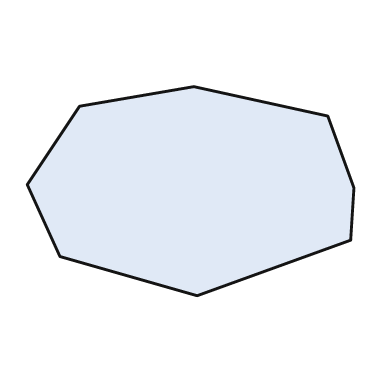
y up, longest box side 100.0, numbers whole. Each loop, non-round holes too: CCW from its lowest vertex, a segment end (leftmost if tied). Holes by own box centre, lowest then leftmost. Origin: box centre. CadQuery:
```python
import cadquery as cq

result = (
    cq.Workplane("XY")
    .moveTo(2.0, -32.0)
    .lineTo(49.0, -15.0)
    .lineTo(50.0, 1.0)
    .lineTo(42.0, 23.0)
    .lineTo(1.0, 32.0)
    .lineTo(-34.0, 26.0)
    .lineTo(-50.0, 2.0)
    .lineTo(-40.0, -20.0)
    .close()
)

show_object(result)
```